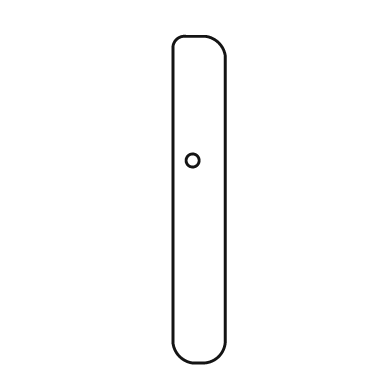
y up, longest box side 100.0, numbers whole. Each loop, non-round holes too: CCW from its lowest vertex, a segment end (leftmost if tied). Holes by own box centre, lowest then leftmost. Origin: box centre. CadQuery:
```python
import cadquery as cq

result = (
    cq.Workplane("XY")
    .moveTo(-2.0, -50.0)
    .lineTo(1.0, -50.0)
    .threePointArc((6.0, -48.0), (8.0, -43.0))
    .lineTo(8.0, 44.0)
    .threePointArc((6.0, 48.0), (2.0, 50.0))
    .lineTo(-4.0, 50.0)
    .threePointArc((-7.0, 49.0), (-8.0, 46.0))
    .lineTo(-8.0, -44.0)
    .threePointArc((-6.0, -48.0), (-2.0, -50.0))
    .close()
    .moveTo(-2.0, 12.0)
    .circle(2.0)
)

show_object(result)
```